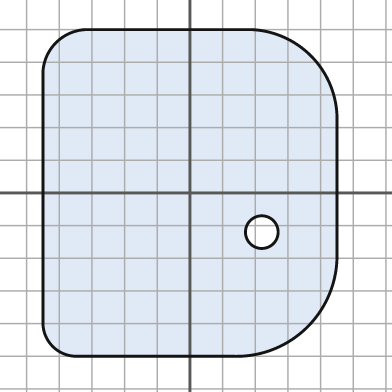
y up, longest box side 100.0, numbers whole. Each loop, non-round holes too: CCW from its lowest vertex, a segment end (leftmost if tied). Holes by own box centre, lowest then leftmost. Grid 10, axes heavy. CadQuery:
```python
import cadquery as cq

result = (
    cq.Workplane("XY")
    .moveTo(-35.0, -50.0)
    .lineTo(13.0, -50.0)
    .threePointArc((36.0, -41.0), (45.0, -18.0))
    .lineTo(45.0, 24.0)
    .threePointArc((37.0, 42.0), (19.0, 50.0))
    .lineTo(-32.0, 50.0)
    .threePointArc((-41.0, 46.0), (-45.0, 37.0))
    .lineTo(-45.0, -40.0)
    .threePointArc((-42.0, -47.0), (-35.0, -50.0))
    .close()
    .moveTo(22.0, -12.0)
    .circle(5.0)
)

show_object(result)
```